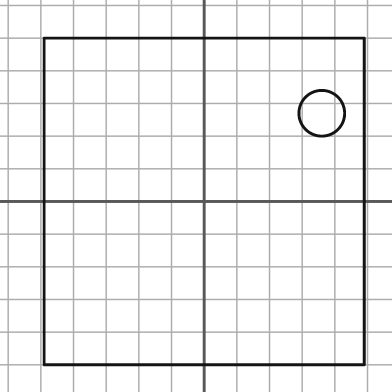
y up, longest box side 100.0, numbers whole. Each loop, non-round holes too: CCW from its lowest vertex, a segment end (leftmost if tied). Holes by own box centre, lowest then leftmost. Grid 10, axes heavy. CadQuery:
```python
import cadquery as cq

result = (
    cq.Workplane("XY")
    .moveTo(-49.0, -50.0)
    .lineTo(49.0, -50.0)
    .lineTo(49.0, 50.0)
    .lineTo(-49.0, 50.0)
    .close()
    .moveTo(36.0, 27.0)
    .circle(7.0)
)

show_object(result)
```